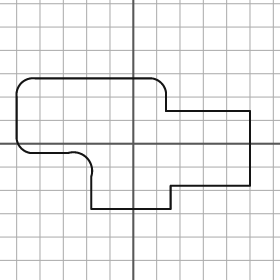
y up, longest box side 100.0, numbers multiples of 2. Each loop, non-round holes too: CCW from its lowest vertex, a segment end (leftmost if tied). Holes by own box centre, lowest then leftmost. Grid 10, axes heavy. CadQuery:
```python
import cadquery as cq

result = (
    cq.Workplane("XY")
    .moveTo(-18.0, -28.0)
    .lineTo(16.0, -28.0)
    .lineTo(16.0, -18.0)
    .lineTo(50.0, -18.0)
    .lineTo(50.0, 14.0)
    .lineTo(14.0, 14.0)
    .lineTo(14.0, 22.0)
    .threePointArc((12.0, 26.0), (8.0, 28.0))
    .lineTo(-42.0, 28.0)
    .threePointArc((-48.0, 26.0), (-50.0, 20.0))
    .lineTo(-50.0, 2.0)
    .threePointArc((-48.0, -2.0), (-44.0, -4.0))
    .lineTo(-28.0, -4.0)
    .threePointArc((-20.0, -6.0), (-18.0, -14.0))
    .close()
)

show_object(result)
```